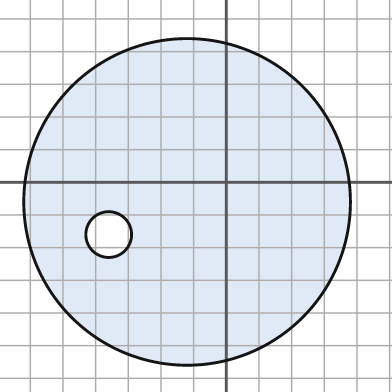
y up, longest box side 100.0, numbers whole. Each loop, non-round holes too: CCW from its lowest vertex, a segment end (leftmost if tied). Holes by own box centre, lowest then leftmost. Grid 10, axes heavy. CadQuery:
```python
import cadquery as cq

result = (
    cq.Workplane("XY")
    .moveTo(-12.0, -6.0)
    .circle(50.0)
    .moveTo(-36.0, -16.0)
    .circle(7.0)
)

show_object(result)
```